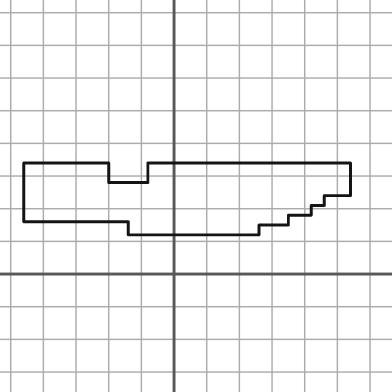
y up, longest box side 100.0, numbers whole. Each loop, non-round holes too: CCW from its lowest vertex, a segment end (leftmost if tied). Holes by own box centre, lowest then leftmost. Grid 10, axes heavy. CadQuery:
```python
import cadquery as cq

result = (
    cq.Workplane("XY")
    .moveTo(-14.0, 12.0)
    .lineTo(26.0, 12.0)
    .lineTo(26.0, 15.0)
    .lineTo(35.0, 15.0)
    .lineTo(35.0, 18.0)
    .lineTo(42.0, 18.0)
    .lineTo(42.0, 21.0)
    .lineTo(46.0, 21.0)
    .lineTo(46.0, 24.0)
    .lineTo(54.0, 24.0)
    .lineTo(54.0, 34.0)
    .lineTo(-8.0, 34.0)
    .lineTo(-8.0, 28.0)
    .lineTo(-20.0, 28.0)
    .lineTo(-20.0, 34.0)
    .lineTo(-46.0, 34.0)
    .lineTo(-46.0, 16.0)
    .lineTo(-14.0, 16.0)
    .close()
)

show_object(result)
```